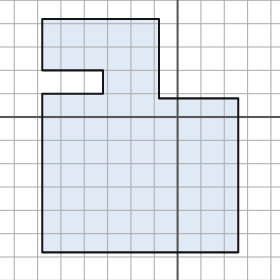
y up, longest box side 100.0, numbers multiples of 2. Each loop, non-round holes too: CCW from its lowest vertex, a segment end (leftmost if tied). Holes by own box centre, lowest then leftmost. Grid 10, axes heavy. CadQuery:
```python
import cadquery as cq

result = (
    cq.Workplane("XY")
    .moveTo(-58.0, -58.0)
    .lineTo(26.0, -58.0)
    .lineTo(26.0, 8.0)
    .lineTo(-8.0, 8.0)
    .lineTo(-8.0, 42.0)
    .lineTo(-58.0, 42.0)
    .lineTo(-58.0, 20.0)
    .lineTo(-32.0, 20.0)
    .lineTo(-32.0, 10.0)
    .lineTo(-58.0, 10.0)
    .close()
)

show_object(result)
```